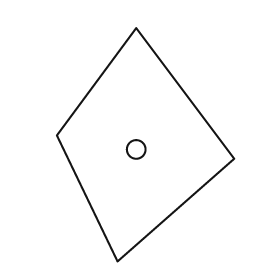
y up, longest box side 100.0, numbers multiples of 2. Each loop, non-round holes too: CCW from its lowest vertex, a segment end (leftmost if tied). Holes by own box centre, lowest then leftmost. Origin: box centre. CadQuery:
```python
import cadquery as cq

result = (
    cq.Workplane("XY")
    .moveTo(-12.0, -50.0)
    .lineTo(38.0, -6.0)
    .lineTo(-4.0, 50.0)
    .lineTo(-38.0, 4.0)
    .close()
    .moveTo(-4.0, -2.0)
    .circle(4.0)
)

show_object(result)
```